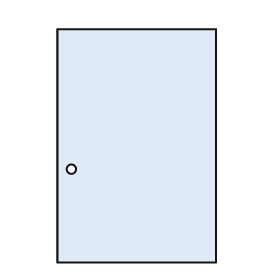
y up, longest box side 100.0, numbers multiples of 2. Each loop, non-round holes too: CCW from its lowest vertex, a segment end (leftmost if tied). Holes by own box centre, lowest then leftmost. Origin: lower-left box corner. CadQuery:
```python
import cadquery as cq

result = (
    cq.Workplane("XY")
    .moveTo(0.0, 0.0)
    .lineTo(68.0, 0.0)
    .lineTo(68.0, 100.0)
    .lineTo(0.0, 100.0)
    .close()
    .moveTo(6.0, 40.0)
    .circle(2.0)
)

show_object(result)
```